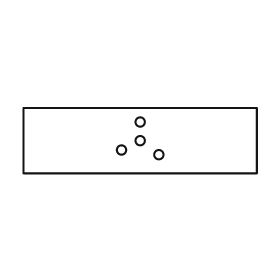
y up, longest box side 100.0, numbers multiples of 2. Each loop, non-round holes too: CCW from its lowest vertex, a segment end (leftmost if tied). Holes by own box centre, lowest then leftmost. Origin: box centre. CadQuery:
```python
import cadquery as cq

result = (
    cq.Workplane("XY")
    .moveTo(-50.0, -14.0)
    .lineTo(50.0, -14.0)
    .lineTo(50.0, 14.0)
    .lineTo(-50.0, 14.0)
    .close()
    .moveTo(8.0, -6.0)
    .circle(2.0)
    .moveTo(-8.0, -4.0)
    .circle(2.0)
    .moveTo(0.0, 0.0)
    .circle(2.0)
    .moveTo(0.0, 8.0)
    .circle(2.0)
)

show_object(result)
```